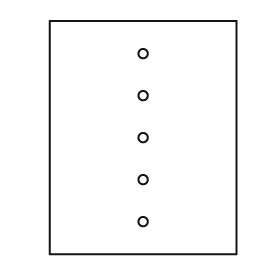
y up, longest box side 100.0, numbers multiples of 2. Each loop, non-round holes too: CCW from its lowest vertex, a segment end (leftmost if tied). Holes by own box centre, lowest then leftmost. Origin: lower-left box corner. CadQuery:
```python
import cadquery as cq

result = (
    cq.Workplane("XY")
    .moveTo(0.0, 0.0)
    .lineTo(80.0, 0.0)
    .lineTo(80.0, 100.0)
    .lineTo(0.0, 100.0)
    .close()
    .moveTo(40.0, 14.0)
    .circle(2.0)
    .moveTo(40.0, 32.0)
    .circle(2.0)
    .moveTo(40.0, 50.0)
    .circle(2.0)
    .moveTo(40.0, 68.0)
    .circle(2.0)
    .moveTo(40.0, 86.0)
    .circle(2.0)
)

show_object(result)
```